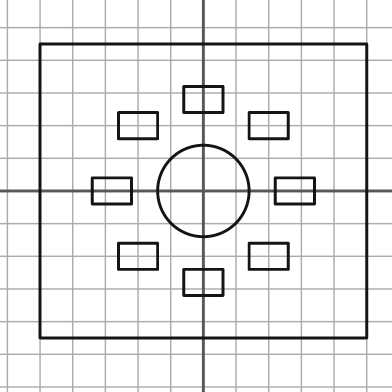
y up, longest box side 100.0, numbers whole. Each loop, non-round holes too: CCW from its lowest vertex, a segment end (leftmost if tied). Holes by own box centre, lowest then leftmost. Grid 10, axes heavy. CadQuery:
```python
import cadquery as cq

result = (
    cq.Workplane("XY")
    .moveTo(-50.0, -45.0)
    .lineTo(50.0, -45.0)
    .lineTo(50.0, 45.0)
    .lineTo(-50.0, 45.0)
    .close()
    .moveTo(-6.0, -32.0)
    .lineTo(6.0, -32.0)
    .lineTo(6.0, -24.0)
    .lineTo(-6.0, -24.0)
    .close()
    .moveTo(-26.0, -24.0)
    .lineTo(-14.0, -24.0)
    .lineTo(-14.0, -16.0)
    .lineTo(-26.0, -16.0)
    .close()
    .moveTo(14.0, -24.0)
    .lineTo(26.0, -24.0)
    .lineTo(26.0, -16.0)
    .lineTo(14.0, -16.0)
    .close()
    .moveTo(-34.0, -4.0)
    .lineTo(-22.0, -4.0)
    .lineTo(-22.0, 4.0)
    .lineTo(-34.0, 4.0)
    .close()
    .moveTo(0.0, 0.0)
    .circle(14.0)
    .moveTo(22.0, -4.0)
    .lineTo(34.0, -4.0)
    .lineTo(34.0, 4.0)
    .lineTo(22.0, 4.0)
    .close()
    .moveTo(-26.0, 16.0)
    .lineTo(-14.0, 16.0)
    .lineTo(-14.0, 24.0)
    .lineTo(-26.0, 24.0)
    .close()
    .moveTo(14.0, 16.0)
    .lineTo(26.0, 16.0)
    .lineTo(26.0, 24.0)
    .lineTo(14.0, 24.0)
    .close()
    .moveTo(-6.0, 24.0)
    .lineTo(6.0, 24.0)
    .lineTo(6.0, 32.0)
    .lineTo(-6.0, 32.0)
    .close()
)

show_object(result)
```